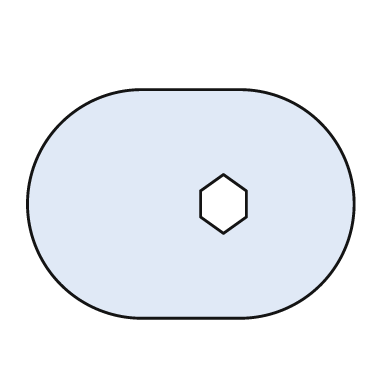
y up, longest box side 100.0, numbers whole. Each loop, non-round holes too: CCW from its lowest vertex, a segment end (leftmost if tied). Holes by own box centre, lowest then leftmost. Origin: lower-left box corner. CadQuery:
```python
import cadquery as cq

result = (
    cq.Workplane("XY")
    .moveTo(35.0, 0.0)
    .lineTo(65.0, 0.0)
    .threePointArc((100.0, 35.0), (65.0, 70.0))
    .lineTo(35.0, 70.0)
    .threePointArc((0.0, 35.0), (35.0, 0.0))
    .close()
    .moveTo(60.0, 26.0)
    .lineTo(67.0, 31.0)
    .lineTo(67.0, 39.0)
    .lineTo(60.0, 44.0)
    .lineTo(53.0, 39.0)
    .lineTo(53.0, 31.0)
    .close()
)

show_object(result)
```